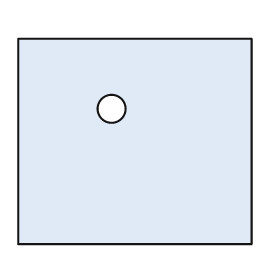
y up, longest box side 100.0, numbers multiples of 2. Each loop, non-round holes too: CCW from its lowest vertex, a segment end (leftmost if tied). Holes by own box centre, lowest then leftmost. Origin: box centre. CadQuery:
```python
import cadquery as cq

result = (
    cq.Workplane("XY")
    .moveTo(-50.0, -44.0)
    .lineTo(50.0, -44.0)
    .lineTo(50.0, 44.0)
    .lineTo(-50.0, 44.0)
    .close()
    .moveTo(-10.0, 14.0)
    .circle(6.0)
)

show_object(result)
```